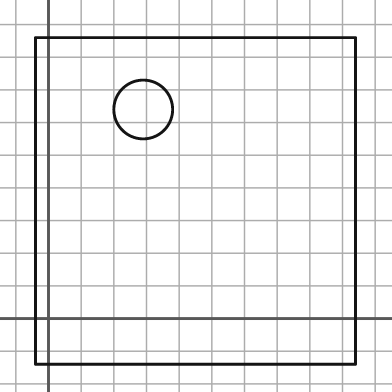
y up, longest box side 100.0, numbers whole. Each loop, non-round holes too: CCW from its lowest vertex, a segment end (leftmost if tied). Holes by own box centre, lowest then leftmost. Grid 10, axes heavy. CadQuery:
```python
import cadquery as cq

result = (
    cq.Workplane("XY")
    .moveTo(-4.0, -14.0)
    .lineTo(94.0, -14.0)
    .lineTo(94.0, 86.0)
    .lineTo(-4.0, 86.0)
    .close()
    .moveTo(29.0, 64.0)
    .circle(9.0)
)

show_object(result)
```